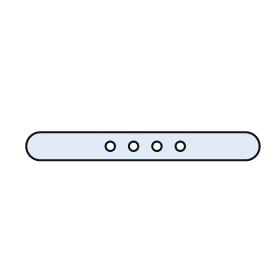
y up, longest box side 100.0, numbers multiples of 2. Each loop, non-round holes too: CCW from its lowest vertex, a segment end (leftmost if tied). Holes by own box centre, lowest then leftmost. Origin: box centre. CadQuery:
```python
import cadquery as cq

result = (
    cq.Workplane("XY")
    .moveTo(-44.0, -6.0)
    .lineTo(44.0, -6.0)
    .threePointArc((50.0, 0.0), (44.0, 6.0))
    .lineTo(-44.0, 6.0)
    .threePointArc((-50.0, 0.0), (-44.0, -6.0))
    .close()
    .moveTo(-14.0, 0.0)
    .circle(2.0)
    .moveTo(-4.0, 0.0)
    .circle(2.0)
    .moveTo(6.0, 0.0)
    .circle(2.0)
    .moveTo(16.0, 0.0)
    .circle(2.0)
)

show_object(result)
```